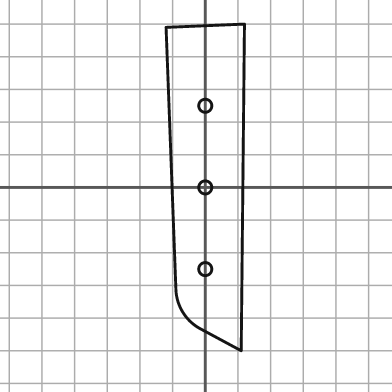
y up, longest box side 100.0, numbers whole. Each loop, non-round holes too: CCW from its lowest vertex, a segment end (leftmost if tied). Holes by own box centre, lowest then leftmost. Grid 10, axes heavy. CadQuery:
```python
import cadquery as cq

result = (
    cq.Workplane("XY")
    .moveTo(11.0, -50.0)
    .lineTo(12.0, 50.0)
    .lineTo(-12.0, 49.0)
    .lineTo(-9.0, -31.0)
    .threePointArc((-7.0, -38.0), (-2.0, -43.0))
    .close()
    .moveTo(0.0, -25.0)
    .circle(2.0)
    .moveTo(0.0, 0.0)
    .circle(2.0)
    .moveTo(0.0, 25.0)
    .circle(2.0)
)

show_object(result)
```